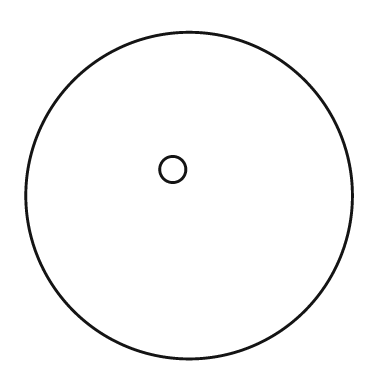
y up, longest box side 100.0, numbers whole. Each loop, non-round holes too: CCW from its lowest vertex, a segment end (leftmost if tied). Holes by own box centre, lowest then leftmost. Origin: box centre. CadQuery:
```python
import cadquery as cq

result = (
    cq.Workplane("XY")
    .moveTo(0.0, 0.0)
    .circle(50.0)
    .moveTo(-5.0, 8.0)
    .circle(4.0)
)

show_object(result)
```